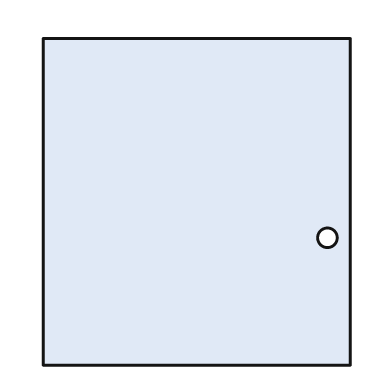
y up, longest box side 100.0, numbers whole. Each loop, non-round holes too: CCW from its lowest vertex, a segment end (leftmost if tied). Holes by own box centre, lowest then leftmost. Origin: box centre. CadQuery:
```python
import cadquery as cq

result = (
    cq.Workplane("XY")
    .moveTo(-47.0, -50.0)
    .lineTo(47.0, -50.0)
    .lineTo(47.0, 50.0)
    .lineTo(-47.0, 50.0)
    .close()
    .moveTo(40.0, -11.0)
    .circle(3.0)
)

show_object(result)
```